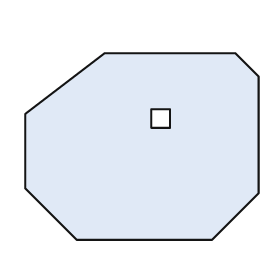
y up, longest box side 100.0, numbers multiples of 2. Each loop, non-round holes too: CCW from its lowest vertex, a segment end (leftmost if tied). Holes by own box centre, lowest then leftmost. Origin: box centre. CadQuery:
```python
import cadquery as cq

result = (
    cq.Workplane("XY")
    .moveTo(-28.0, -40.0)
    .lineTo(30.0, -40.0)
    .lineTo(50.0, -20.0)
    .lineTo(50.0, 30.0)
    .lineTo(40.0, 40.0)
    .lineTo(-16.0, 40.0)
    .lineTo(-50.0, 14.0)
    .lineTo(-50.0, -18.0)
    .close()
    .moveTo(4.0, 8.0)
    .lineTo(12.0, 8.0)
    .lineTo(12.0, 16.0)
    .lineTo(4.0, 16.0)
    .close()
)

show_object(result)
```